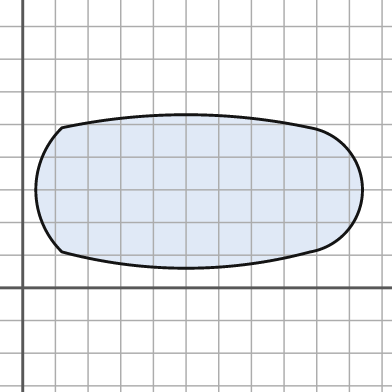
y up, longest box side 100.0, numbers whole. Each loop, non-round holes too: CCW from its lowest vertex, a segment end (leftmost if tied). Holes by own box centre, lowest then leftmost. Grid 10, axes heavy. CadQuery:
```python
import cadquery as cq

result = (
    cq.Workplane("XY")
    .moveTo(12.0, 11.0)
    .threePointArc((50.0, 6.0), (88.0, 11.0))
    .threePointArc((104.0, 30.0), (88.0, 49.0))
    .threePointArc((50.0, 53.0), (12.0, 49.0))
    .threePointArc((4.0, 30.0), (12.0, 11.0))
    .close()
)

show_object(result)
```